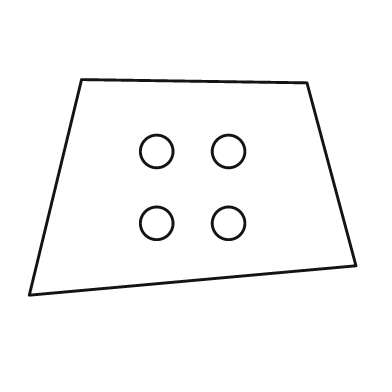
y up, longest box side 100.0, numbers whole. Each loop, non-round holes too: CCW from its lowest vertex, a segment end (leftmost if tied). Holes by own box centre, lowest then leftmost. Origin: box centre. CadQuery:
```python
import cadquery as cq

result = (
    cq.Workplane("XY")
    .moveTo(-50.0, -33.0)
    .lineTo(50.0, -24.0)
    .lineTo(35.0, 32.0)
    .lineTo(-34.0, 33.0)
    .close()
    .moveTo(-11.0, -11.0)
    .circle(5.0)
    .moveTo(11.0, -11.0)
    .circle(5.0)
    .moveTo(-11.0, 11.0)
    .circle(5.0)
    .moveTo(11.0, 11.0)
    .circle(5.0)
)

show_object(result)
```